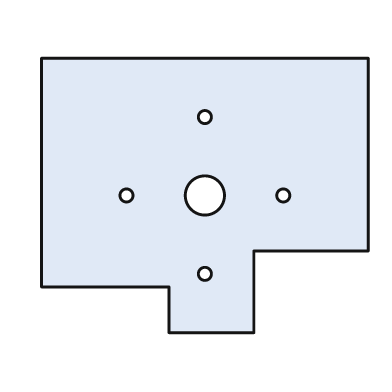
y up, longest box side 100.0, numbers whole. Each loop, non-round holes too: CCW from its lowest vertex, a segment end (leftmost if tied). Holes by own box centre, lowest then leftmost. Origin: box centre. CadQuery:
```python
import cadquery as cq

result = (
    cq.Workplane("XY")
    .moveTo(-11.0, -42.0)
    .lineTo(15.0, -42.0)
    .lineTo(15.0, -17.0)
    .lineTo(50.0, -17.0)
    .lineTo(50.0, 42.0)
    .lineTo(-50.0, 42.0)
    .lineTo(-50.0, -28.0)
    .lineTo(-11.0, -28.0)
    .close()
    .moveTo(0.0, -24.0)
    .circle(2.0)
    .moveTo(-24.0, 0.0)
    .circle(2.0)
    .moveTo(0.0, 0.0)
    .circle(6.0)
    .moveTo(24.0, 0.0)
    .circle(2.0)
    .moveTo(0.0, 24.0)
    .circle(2.0)
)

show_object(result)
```